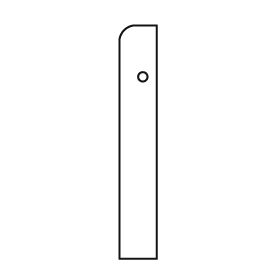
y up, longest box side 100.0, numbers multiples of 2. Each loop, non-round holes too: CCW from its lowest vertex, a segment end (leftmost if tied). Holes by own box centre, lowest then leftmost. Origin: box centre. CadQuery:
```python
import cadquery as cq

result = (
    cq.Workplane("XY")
    .moveTo(-8.0, -50.0)
    .lineTo(8.0, -50.0)
    .lineTo(8.0, 50.0)
    .lineTo(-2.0, 50.0)
    .threePointArc((-6.0, 48.0), (-8.0, 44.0))
    .close()
    .moveTo(2.0, 28.0)
    .circle(2.0)
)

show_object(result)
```